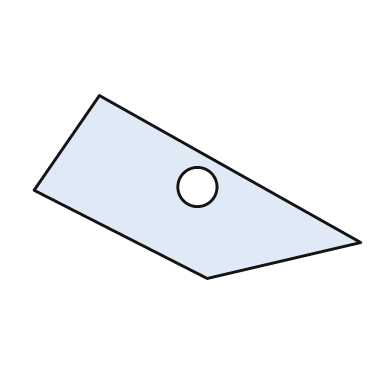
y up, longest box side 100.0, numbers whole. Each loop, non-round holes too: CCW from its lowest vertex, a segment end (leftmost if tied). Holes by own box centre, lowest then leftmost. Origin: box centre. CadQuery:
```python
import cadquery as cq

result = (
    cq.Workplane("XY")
    .moveTo(3.0, -28.0)
    .lineTo(50.0, -17.0)
    .lineTo(-30.0, 28.0)
    .lineTo(-50.0, -1.0)
    .close()
    .moveTo(0.0, 0.0)
    .circle(6.0)
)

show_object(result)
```